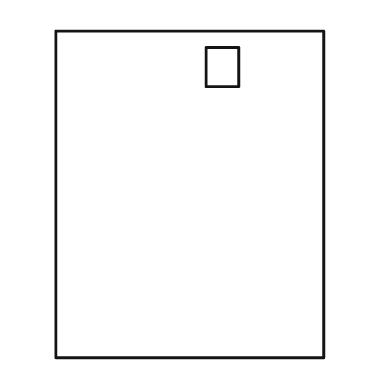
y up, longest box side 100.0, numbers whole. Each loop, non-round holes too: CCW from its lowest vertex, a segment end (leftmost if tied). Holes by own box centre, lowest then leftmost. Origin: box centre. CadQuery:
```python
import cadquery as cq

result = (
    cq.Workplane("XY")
    .moveTo(-41.0, -50.0)
    .lineTo(41.0, -50.0)
    .lineTo(41.0, 50.0)
    .lineTo(-41.0, 50.0)
    .close()
    .moveTo(5.0, 33.0)
    .lineTo(15.0, 33.0)
    .lineTo(15.0, 45.0)
    .lineTo(5.0, 45.0)
    .close()
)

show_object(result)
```